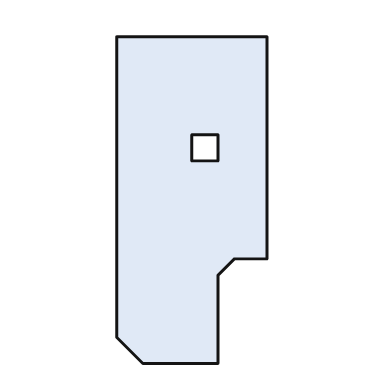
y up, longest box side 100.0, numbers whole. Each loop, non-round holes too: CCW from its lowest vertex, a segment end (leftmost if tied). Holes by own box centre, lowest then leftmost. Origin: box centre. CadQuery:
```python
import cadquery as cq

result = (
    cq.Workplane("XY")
    .moveTo(-15.0, -50.0)
    .lineTo(8.0, -50.0)
    .lineTo(8.0, -23.0)
    .lineTo(13.0, -18.0)
    .lineTo(23.0, -18.0)
    .lineTo(23.0, 50.0)
    .lineTo(-23.0, 50.0)
    .lineTo(-23.0, -42.0)
    .close()
    .moveTo(0.0, 12.0)
    .lineTo(8.0, 12.0)
    .lineTo(8.0, 20.0)
    .lineTo(0.0, 20.0)
    .close()
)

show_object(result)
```